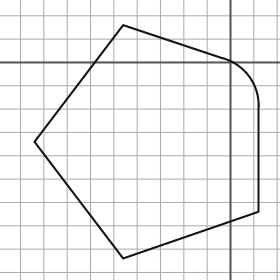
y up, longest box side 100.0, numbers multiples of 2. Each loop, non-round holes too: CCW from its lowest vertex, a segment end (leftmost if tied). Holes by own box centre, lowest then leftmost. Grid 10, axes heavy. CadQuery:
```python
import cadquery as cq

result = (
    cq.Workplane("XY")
    .moveTo(-46.0, -84.0)
    .lineTo(12.0, -64.0)
    .lineTo(12.0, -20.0)
    .threePointArc((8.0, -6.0), (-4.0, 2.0))
    .lineTo(-46.0, 16.0)
    .lineTo(-84.0, -34.0)
    .close()
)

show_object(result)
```